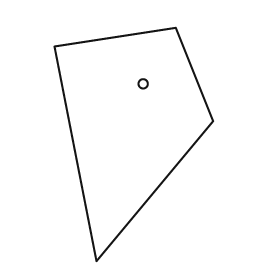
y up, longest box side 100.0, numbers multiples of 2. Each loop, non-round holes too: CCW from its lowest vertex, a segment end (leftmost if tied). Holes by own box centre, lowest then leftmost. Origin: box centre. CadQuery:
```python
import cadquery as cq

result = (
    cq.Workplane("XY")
    .moveTo(-16.0, -50.0)
    .lineTo(34.0, 10.0)
    .lineTo(18.0, 50.0)
    .lineTo(-34.0, 42.0)
    .close()
    .moveTo(4.0, 26.0)
    .circle(2.0)
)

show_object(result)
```